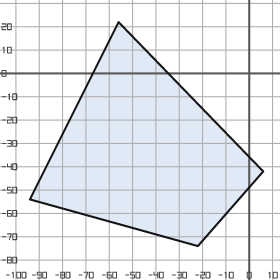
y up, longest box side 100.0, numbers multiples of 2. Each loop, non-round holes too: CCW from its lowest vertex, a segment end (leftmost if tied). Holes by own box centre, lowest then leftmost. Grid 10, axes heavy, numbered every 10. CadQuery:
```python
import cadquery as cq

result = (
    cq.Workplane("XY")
    .moveTo(-22.0, -74.0)
    .lineTo(6.0, -42.0)
    .lineTo(-56.0, 22.0)
    .lineTo(-94.0, -54.0)
    .close()
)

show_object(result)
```